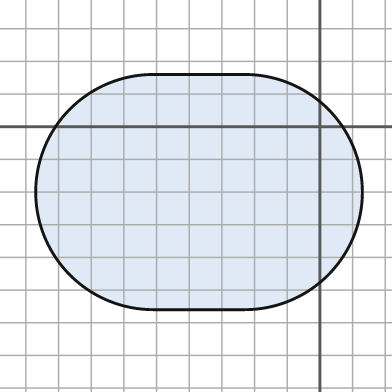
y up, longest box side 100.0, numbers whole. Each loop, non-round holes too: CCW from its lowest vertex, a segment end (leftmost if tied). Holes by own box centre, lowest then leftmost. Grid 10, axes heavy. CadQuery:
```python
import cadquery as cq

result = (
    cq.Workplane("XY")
    .moveTo(-51.0, -56.0)
    .lineTo(-23.0, -56.0)
    .threePointArc((13.0, -20.0), (-23.0, 16.0))
    .lineTo(-51.0, 16.0)
    .threePointArc((-87.0, -20.0), (-51.0, -56.0))
    .close()
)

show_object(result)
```